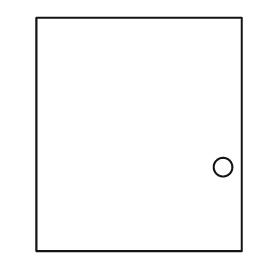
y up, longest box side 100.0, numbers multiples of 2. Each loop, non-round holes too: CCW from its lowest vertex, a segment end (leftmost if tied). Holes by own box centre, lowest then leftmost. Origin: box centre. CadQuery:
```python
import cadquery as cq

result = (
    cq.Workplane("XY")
    .moveTo(-44.0, -50.0)
    .lineTo(44.0, -50.0)
    .lineTo(44.0, 50.0)
    .lineTo(-44.0, 50.0)
    .close()
    .moveTo(36.0, -14.0)
    .circle(4.0)
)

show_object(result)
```